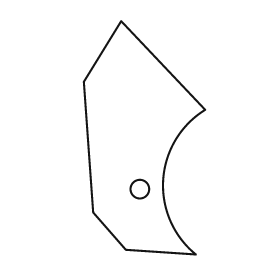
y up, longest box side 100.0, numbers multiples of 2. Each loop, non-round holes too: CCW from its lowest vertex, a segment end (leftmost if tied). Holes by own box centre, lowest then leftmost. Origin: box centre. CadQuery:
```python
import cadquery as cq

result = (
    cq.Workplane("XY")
    .moveTo(22.0, -50.0)
    .threePointArc((8.0, -18.0), (26.0, 12.0))
    .lineTo(-10.0, 50.0)
    .lineTo(-26.0, 24.0)
    .lineTo(-22.0, -32.0)
    .lineTo(-8.0, -48.0)
    .close()
    .moveTo(-2.0, -22.0)
    .circle(4.0)
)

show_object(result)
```